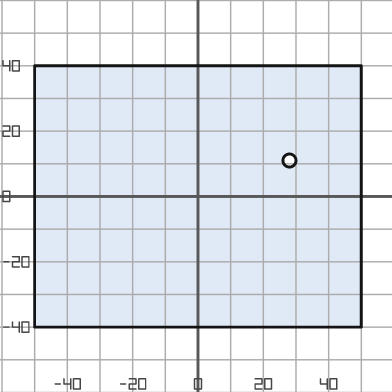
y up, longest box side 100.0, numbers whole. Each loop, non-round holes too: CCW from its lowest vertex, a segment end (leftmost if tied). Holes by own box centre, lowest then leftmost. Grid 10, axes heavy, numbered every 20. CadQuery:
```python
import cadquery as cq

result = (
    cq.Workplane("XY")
    .moveTo(-50.0, -40.0)
    .lineTo(50.0, -40.0)
    .lineTo(50.0, 40.0)
    .lineTo(-50.0, 40.0)
    .close()
    .moveTo(28.0, 11.0)
    .circle(2.0)
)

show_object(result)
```